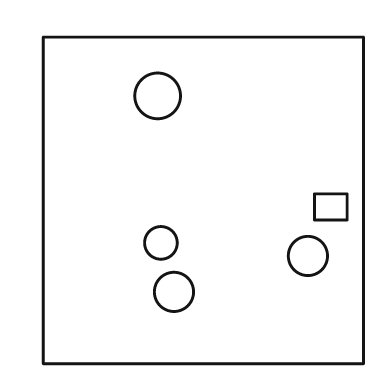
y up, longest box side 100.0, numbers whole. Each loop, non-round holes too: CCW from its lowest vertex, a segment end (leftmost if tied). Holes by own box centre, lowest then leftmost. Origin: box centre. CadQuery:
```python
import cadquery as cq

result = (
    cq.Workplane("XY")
    .moveTo(-49.0, -50.0)
    .lineTo(49.0, -50.0)
    .lineTo(49.0, 50.0)
    .lineTo(-49.0, 50.0)
    .close()
    .moveTo(-9.0, -28.0)
    .circle(6.0)
    .moveTo(32.0, -17.0)
    .circle(6.0)
    .moveTo(-13.0, -13.0)
    .circle(5.0)
    .moveTo(34.0, -6.0)
    .lineTo(44.0, -6.0)
    .lineTo(44.0, 2.0)
    .lineTo(34.0, 2.0)
    .close()
    .moveTo(-14.0, 32.0)
    .circle(7.0)
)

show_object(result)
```